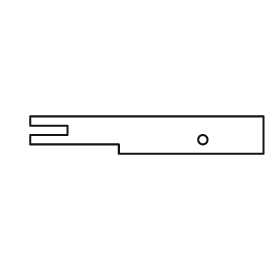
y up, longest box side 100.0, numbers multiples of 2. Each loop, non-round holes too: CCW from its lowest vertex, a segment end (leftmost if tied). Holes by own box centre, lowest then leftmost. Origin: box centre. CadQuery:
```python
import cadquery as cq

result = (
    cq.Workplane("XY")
    .moveTo(-12.0, -8.0)
    .lineTo(50.0, -8.0)
    .lineTo(50.0, 8.0)
    .lineTo(-50.0, 8.0)
    .lineTo(-50.0, 4.0)
    .lineTo(-34.0, 4.0)
    .lineTo(-34.0, 0.0)
    .lineTo(-50.0, 0.0)
    .lineTo(-50.0, -4.0)
    .lineTo(-12.0, -4.0)
    .close()
    .moveTo(24.0, -2.0)
    .circle(2.0)
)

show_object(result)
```